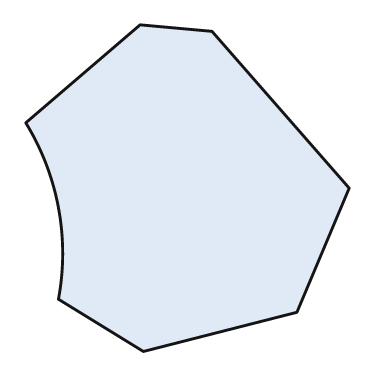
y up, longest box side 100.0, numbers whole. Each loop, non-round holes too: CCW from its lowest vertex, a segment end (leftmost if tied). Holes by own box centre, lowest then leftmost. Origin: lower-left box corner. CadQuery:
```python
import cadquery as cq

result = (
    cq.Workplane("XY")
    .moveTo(36.0, 0.0)
    .lineTo(83.0, 12.0)
    .lineTo(99.0, 50.0)
    .lineTo(57.0, 98.0)
    .lineTo(35.0, 100.0)
    .lineTo(0.0, 70.0)
    .threePointArc((10.0, 44.0), (10.0, 16.0))
    .close()
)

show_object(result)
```